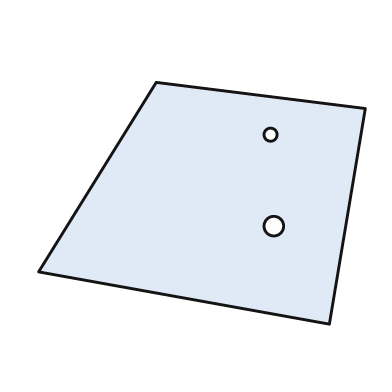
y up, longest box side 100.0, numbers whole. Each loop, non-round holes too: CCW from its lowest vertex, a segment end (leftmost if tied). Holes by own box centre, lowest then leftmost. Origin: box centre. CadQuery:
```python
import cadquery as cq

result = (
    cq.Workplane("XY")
    .moveTo(39.0, -37.0)
    .lineTo(50.0, 29.0)
    .lineTo(-14.0, 37.0)
    .lineTo(-50.0, -21.0)
    .close()
    .moveTo(22.0, -7.0)
    .circle(3.0)
    .moveTo(21.0, 21.0)
    .circle(2.0)
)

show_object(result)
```